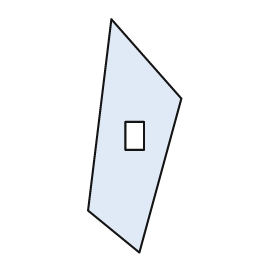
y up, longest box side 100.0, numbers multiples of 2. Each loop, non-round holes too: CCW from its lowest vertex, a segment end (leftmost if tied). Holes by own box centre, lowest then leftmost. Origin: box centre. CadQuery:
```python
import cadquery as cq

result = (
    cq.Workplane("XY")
    .moveTo(2.0, -50.0)
    .lineTo(20.0, 16.0)
    .lineTo(-10.0, 50.0)
    .lineTo(-20.0, -32.0)
    .close()
    .moveTo(-4.0, -6.0)
    .lineTo(4.0, -6.0)
    .lineTo(4.0, 6.0)
    .lineTo(-4.0, 6.0)
    .close()
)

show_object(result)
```